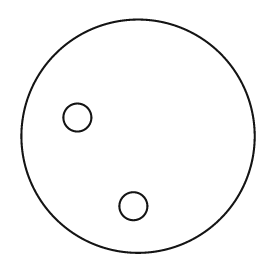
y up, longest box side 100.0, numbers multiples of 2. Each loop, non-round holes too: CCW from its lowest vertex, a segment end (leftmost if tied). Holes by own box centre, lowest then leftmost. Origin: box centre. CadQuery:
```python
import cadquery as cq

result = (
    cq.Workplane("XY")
    .moveTo(0.0, 0.0)
    .circle(50.0)
    .moveTo(-2.0, -30.0)
    .circle(6.0)
    .moveTo(-26.0, 8.0)
    .circle(6.0)
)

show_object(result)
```